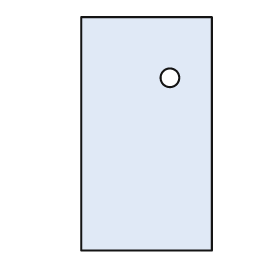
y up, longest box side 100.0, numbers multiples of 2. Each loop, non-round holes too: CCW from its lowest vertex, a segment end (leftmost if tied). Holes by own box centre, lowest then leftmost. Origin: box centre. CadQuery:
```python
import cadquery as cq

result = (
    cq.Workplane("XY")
    .moveTo(-28.0, -50.0)
    .lineTo(28.0, -50.0)
    .lineTo(28.0, 50.0)
    .lineTo(-28.0, 50.0)
    .close()
    .moveTo(10.0, 24.0)
    .circle(4.0)
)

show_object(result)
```